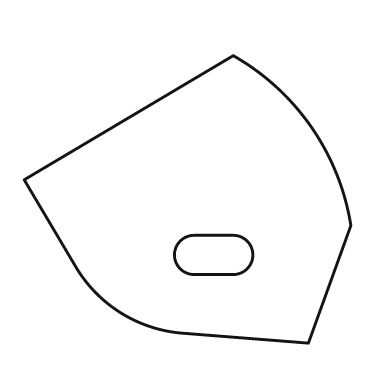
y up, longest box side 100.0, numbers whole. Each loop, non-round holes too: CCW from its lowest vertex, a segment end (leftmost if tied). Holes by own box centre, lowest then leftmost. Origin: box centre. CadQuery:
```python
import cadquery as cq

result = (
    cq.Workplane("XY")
    .moveTo(37.0, -44.0)
    .lineTo(50.0, -8.0)
    .threePointArc((38.0, 22.0), (14.0, 44.0))
    .lineTo(-50.0, 6.0)
    .lineTo(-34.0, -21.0)
    .threePointArc((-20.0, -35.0), (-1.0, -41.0))
    .close()
    .moveTo(2.0, -23.0)
    .lineTo(14.0, -23.0)
    .threePointArc((20.0, -17.0), (14.0, -11.0))
    .lineTo(2.0, -11.0)
    .threePointArc((-4.0, -17.0), (2.0, -23.0))
    .close()
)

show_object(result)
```